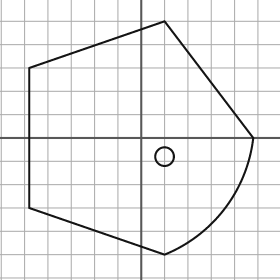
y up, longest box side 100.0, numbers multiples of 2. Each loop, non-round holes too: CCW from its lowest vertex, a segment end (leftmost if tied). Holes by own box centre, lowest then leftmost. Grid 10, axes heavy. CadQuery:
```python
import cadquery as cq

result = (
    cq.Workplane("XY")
    .moveTo(10.0, -50.0)
    .threePointArc((36.0, -30.0), (48.0, 0.0))
    .lineTo(10.0, 50.0)
    .lineTo(-48.0, 30.0)
    .lineTo(-48.0, -30.0)
    .close()
    .moveTo(10.0, -8.0)
    .circle(4.0)
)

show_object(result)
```